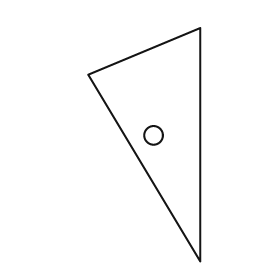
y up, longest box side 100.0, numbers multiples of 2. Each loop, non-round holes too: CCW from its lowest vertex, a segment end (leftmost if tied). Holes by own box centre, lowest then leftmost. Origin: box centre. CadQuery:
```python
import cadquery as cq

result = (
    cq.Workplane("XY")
    .moveTo(24.0, -50.0)
    .lineTo(24.0, 50.0)
    .lineTo(-24.0, 30.0)
    .close()
    .moveTo(4.0, 4.0)
    .circle(4.0)
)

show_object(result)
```